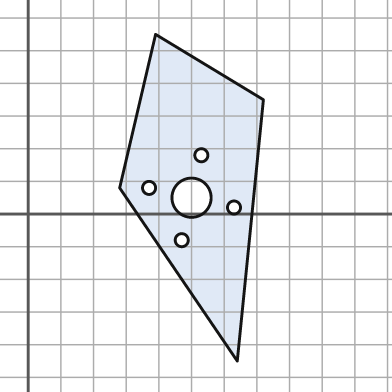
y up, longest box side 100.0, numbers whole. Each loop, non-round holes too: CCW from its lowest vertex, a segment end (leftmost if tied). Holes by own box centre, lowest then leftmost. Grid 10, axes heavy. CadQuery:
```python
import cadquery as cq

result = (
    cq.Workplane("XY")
    .moveTo(64.0, -45.0)
    .lineTo(72.0, 35.0)
    .lineTo(39.0, 55.0)
    .lineTo(28.0, 8.0)
    .close()
    .moveTo(47.0, -8.0)
    .circle(2.0)
    .moveTo(63.0, 2.0)
    .circle(2.0)
    .moveTo(50.0, 5.0)
    .circle(6.0)
    .moveTo(37.0, 8.0)
    .circle(2.0)
    .moveTo(53.0, 18.0)
    .circle(2.0)
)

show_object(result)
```